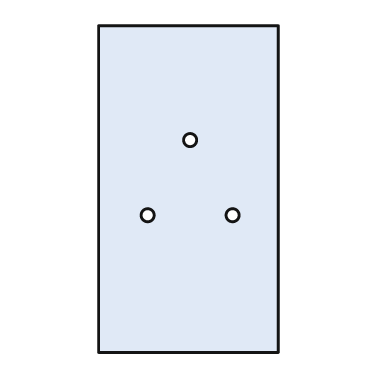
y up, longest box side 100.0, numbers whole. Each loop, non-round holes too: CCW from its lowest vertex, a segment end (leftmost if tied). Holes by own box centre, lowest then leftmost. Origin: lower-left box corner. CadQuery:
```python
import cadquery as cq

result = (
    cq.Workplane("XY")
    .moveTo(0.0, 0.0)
    .lineTo(55.0, 0.0)
    .lineTo(55.0, 100.0)
    .lineTo(0.0, 100.0)
    .close()
    .moveTo(15.0, 42.0)
    .circle(2.0)
    .moveTo(41.0, 42.0)
    .circle(2.0)
    .moveTo(28.0, 65.0)
    .circle(2.0)
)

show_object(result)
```